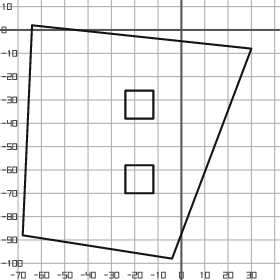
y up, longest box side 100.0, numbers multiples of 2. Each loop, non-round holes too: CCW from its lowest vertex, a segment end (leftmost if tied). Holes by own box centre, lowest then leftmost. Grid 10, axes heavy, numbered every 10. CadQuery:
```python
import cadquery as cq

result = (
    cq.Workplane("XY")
    .moveTo(-4.0, -98.0)
    .lineTo(30.0, -8.0)
    .lineTo(-64.0, 2.0)
    .lineTo(-68.0, -88.0)
    .close()
    .moveTo(-24.0, -70.0)
    .lineTo(-12.0, -70.0)
    .lineTo(-12.0, -58.0)
    .lineTo(-24.0, -58.0)
    .close()
    .moveTo(-24.0, -38.0)
    .lineTo(-12.0, -38.0)
    .lineTo(-12.0, -26.0)
    .lineTo(-24.0, -26.0)
    .close()
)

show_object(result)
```